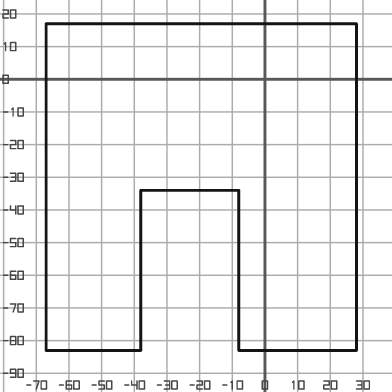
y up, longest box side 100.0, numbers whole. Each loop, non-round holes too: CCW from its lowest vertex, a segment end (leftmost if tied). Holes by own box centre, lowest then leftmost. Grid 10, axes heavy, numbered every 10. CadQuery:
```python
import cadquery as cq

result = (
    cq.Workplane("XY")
    .moveTo(-67.0, -83.0)
    .lineTo(-38.0, -83.0)
    .lineTo(-38.0, -34.0)
    .lineTo(-8.0, -34.0)
    .lineTo(-8.0, -83.0)
    .lineTo(28.0, -83.0)
    .lineTo(28.0, 17.0)
    .lineTo(-67.0, 17.0)
    .close()
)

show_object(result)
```